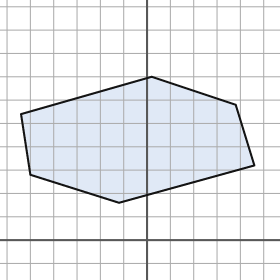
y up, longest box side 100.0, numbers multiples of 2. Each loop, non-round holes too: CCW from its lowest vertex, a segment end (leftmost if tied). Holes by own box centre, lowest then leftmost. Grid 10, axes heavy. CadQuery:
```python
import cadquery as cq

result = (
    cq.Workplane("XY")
    .moveTo(-12.0, 16.0)
    .lineTo(46.0, 32.0)
    .lineTo(38.0, 58.0)
    .lineTo(2.0, 70.0)
    .lineTo(-54.0, 54.0)
    .lineTo(-50.0, 28.0)
    .close()
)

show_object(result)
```